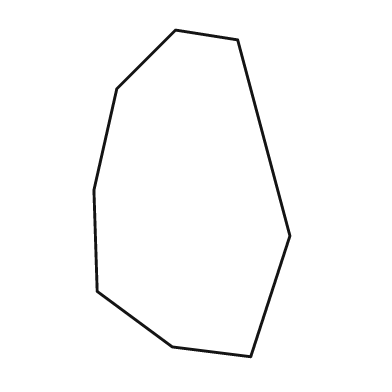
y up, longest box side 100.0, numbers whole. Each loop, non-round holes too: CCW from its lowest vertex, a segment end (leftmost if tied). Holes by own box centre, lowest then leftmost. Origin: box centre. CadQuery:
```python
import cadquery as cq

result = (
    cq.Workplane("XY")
    .moveTo(18.0, -50.0)
    .lineTo(30.0, -13.0)
    .lineTo(14.0, 47.0)
    .lineTo(-5.0, 50.0)
    .lineTo(-23.0, 32.0)
    .lineTo(-30.0, 1.0)
    .lineTo(-29.0, -30.0)
    .lineTo(-6.0, -47.0)
    .close()
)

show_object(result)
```